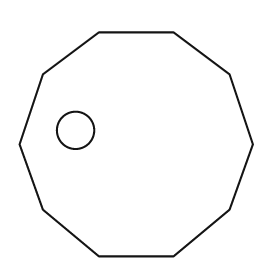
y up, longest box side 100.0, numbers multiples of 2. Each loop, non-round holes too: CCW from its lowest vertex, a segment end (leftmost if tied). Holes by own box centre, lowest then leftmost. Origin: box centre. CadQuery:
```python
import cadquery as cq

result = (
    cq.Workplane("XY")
    .moveTo(-16.0, -48.0)
    .lineTo(16.0, -48.0)
    .lineTo(40.0, -28.0)
    .lineTo(50.0, 0.0)
    .lineTo(40.0, 30.0)
    .lineTo(16.0, 48.0)
    .lineTo(-16.0, 48.0)
    .lineTo(-40.0, 30.0)
    .lineTo(-50.0, 0.0)
    .lineTo(-40.0, -28.0)
    .close()
    .moveTo(-26.0, 6.0)
    .circle(8.0)
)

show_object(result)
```